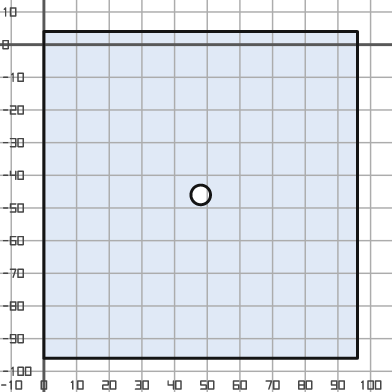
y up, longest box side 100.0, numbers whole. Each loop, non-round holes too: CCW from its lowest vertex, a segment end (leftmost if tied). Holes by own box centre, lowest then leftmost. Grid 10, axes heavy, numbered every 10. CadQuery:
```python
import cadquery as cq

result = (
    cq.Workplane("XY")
    .moveTo(0.0, -96.0)
    .lineTo(96.0, -96.0)
    .lineTo(96.0, 4.0)
    .lineTo(0.0, 4.0)
    .close()
    .moveTo(48.0, -46.0)
    .circle(3.0)
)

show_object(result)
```